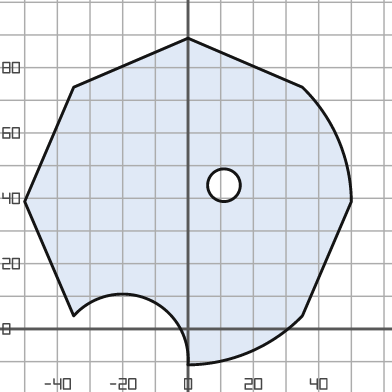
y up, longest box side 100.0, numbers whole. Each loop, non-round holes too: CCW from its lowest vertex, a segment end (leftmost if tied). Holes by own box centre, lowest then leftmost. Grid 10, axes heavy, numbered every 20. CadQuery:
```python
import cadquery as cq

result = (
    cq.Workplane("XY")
    .moveTo(0.0, -11.0)
    .threePointArc((19.0, -7.0), (35.0, 4.0))
    .lineTo(50.0, 39.0)
    .threePointArc((46.0, 58.0), (35.0, 74.0))
    .lineTo(0.0, 89.0)
    .lineTo(-35.0, 74.0)
    .lineTo(-50.0, 39.0)
    .lineTo(-35.0, 4.0)
    .threePointArc((-12.0, 9.0), (0.0, -11.0))
    .close()
    .moveTo(11.0, 44.0)
    .circle(5.0)
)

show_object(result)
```